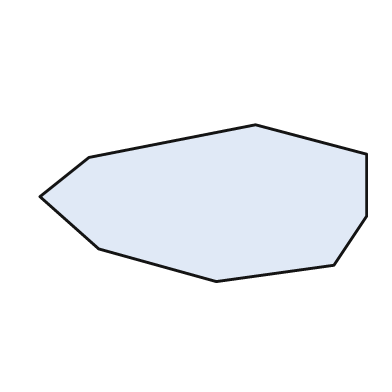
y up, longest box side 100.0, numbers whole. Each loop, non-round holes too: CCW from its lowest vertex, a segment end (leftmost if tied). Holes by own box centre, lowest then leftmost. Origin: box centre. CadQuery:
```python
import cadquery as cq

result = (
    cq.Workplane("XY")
    .moveTo(4.0, -24.0)
    .lineTo(40.0, -19.0)
    .lineTo(50.0, -4.0)
    .lineTo(50.0, 15.0)
    .lineTo(16.0, 24.0)
    .lineTo(-35.0, 14.0)
    .lineTo(-50.0, 2.0)
    .lineTo(-32.0, -14.0)
    .close()
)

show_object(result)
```